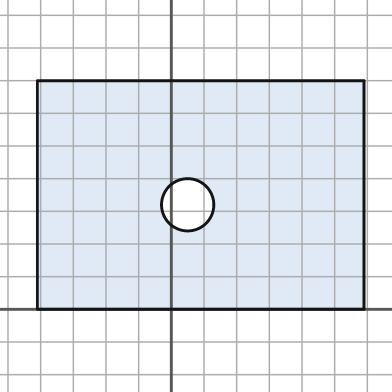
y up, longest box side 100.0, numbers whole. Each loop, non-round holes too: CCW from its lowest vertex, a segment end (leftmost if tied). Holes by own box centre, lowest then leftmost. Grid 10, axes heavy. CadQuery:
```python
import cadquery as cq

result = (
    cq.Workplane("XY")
    .moveTo(-41.0, 0.0)
    .lineTo(59.0, 0.0)
    .lineTo(59.0, 70.0)
    .lineTo(-41.0, 70.0)
    .close()
    .moveTo(5.0, 32.0)
    .circle(8.0)
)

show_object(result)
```